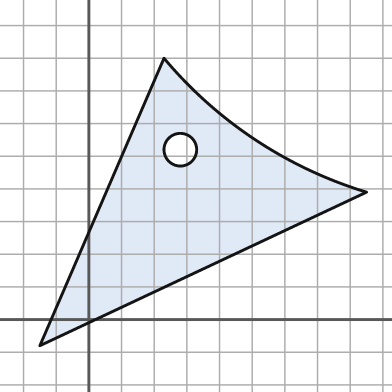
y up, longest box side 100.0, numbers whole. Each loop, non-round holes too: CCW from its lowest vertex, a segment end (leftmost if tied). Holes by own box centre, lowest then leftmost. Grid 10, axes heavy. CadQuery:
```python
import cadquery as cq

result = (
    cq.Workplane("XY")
    .moveTo(-15.0, -8.0)
    .lineTo(85.0, 39.0)
    .threePointArc((51.0, 55.0), (23.0, 80.0))
    .close()
    .moveTo(28.0, 52.0)
    .circle(5.0)
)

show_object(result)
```